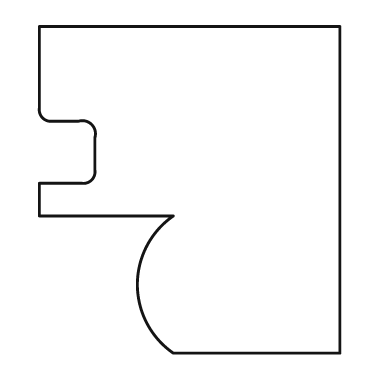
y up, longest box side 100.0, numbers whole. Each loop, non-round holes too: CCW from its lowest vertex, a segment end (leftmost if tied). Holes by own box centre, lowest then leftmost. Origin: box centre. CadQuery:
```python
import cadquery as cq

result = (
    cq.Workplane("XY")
    .moveTo(-5.0, -50.0)
    .lineTo(46.0, -50.0)
    .lineTo(46.0, 50.0)
    .lineTo(-46.0, 50.0)
    .lineTo(-46.0, 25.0)
    .threePointArc((-45.0, 22.0), (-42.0, 21.0))
    .lineTo(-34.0, 21.0)
    .threePointArc((-30.0, 20.0), (-29.0, 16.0))
    .lineTo(-29.0, 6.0)
    .threePointArc((-30.0, 3.0), (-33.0, 2.0))
    .lineTo(-46.0, 2.0)
    .lineTo(-46.0, -8.0)
    .lineTo(-5.0, -8.0)
    .threePointArc((-16.0, -29.0), (-5.0, -50.0))
    .close()
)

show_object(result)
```